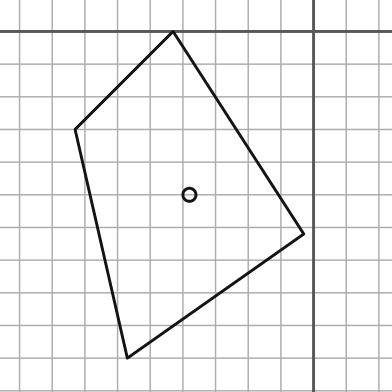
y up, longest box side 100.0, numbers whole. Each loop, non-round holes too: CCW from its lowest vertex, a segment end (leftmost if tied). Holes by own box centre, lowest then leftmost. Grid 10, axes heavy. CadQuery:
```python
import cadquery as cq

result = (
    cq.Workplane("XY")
    .moveTo(-57.0, -100.0)
    .lineTo(-3.0, -62.0)
    .lineTo(-43.0, 0.0)
    .lineTo(-73.0, -30.0)
    .close()
    .moveTo(-38.0, -50.0)
    .circle(2.0)
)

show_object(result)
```